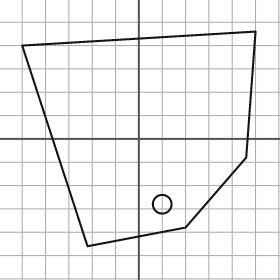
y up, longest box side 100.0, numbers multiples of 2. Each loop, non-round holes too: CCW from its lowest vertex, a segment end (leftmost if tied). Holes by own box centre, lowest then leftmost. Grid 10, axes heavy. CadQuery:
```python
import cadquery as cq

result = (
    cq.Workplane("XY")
    .moveTo(-22.0, -46.0)
    .lineTo(20.0, -38.0)
    .lineTo(46.0, -8.0)
    .lineTo(50.0, 46.0)
    .lineTo(-50.0, 40.0)
    .close()
    .moveTo(10.0, -28.0)
    .circle(4.0)
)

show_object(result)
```